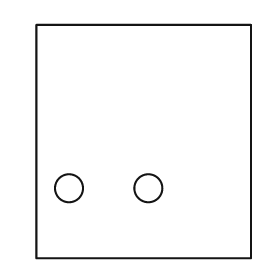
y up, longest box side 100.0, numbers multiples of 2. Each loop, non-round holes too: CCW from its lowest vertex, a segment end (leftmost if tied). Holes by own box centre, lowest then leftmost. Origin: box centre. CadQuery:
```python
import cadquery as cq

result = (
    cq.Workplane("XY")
    .moveTo(-46.0, -50.0)
    .lineTo(46.0, -50.0)
    .lineTo(46.0, 50.0)
    .lineTo(-46.0, 50.0)
    .close()
    .moveTo(-32.0, -20.0)
    .circle(6.0)
    .moveTo(2.0, -20.0)
    .circle(6.0)
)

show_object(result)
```